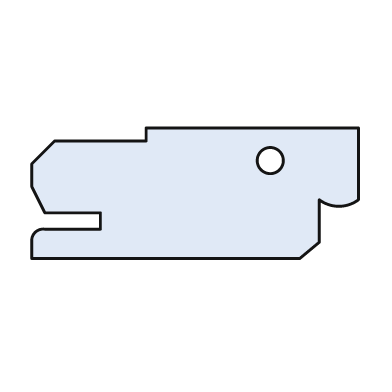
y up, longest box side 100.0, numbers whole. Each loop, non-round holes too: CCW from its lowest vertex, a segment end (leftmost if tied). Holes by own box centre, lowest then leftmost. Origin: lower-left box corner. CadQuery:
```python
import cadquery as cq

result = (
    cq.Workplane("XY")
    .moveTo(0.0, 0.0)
    .lineTo(82.0, 0.0)
    .lineTo(88.0, 5.0)
    .lineTo(88.0, 18.0)
    .threePointArc((94.0, 16.0), (100.0, 18.0))
    .lineTo(100.0, 40.0)
    .lineTo(35.0, 40.0)
    .lineTo(35.0, 36.0)
    .lineTo(7.0, 36.0)
    .lineTo(0.0, 29.0)
    .lineTo(0.0, 22.0)
    .lineTo(4.0, 14.0)
    .lineTo(21.0, 14.0)
    .lineTo(21.0, 9.0)
    .lineTo(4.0, 9.0)
    .threePointArc((1.0, 8.0), (0.0, 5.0))
    .close()
    .moveTo(73.0, 30.0)
    .circle(4.0)
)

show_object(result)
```